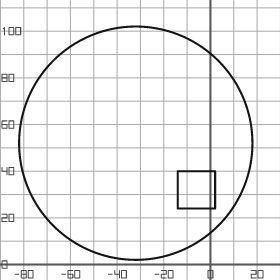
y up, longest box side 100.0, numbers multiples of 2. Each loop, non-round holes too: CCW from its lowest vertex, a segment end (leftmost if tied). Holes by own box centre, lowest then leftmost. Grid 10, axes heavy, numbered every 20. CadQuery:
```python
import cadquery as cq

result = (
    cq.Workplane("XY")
    .moveTo(-32.0, 52.0)
    .circle(50.0)
    .moveTo(-14.0, 24.0)
    .lineTo(2.0, 24.0)
    .lineTo(2.0, 40.0)
    .lineTo(-14.0, 40.0)
    .close()
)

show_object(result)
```